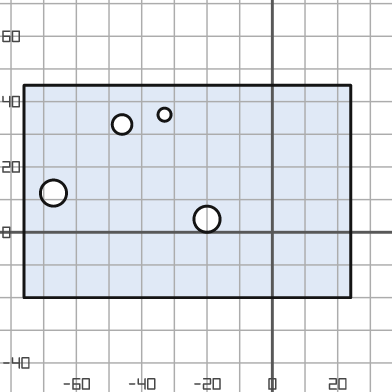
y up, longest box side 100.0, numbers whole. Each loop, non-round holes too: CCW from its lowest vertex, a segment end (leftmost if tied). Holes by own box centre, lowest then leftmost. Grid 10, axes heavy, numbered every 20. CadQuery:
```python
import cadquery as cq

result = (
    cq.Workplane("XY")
    .moveTo(-76.0, -20.0)
    .lineTo(24.0, -20.0)
    .lineTo(24.0, 45.0)
    .lineTo(-76.0, 45.0)
    .close()
    .moveTo(-20.0, 4.0)
    .circle(4.0)
    .moveTo(-67.0, 12.0)
    .circle(4.0)
    .moveTo(-46.0, 33.0)
    .circle(3.0)
    .moveTo(-33.0, 36.0)
    .circle(2.0)
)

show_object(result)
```